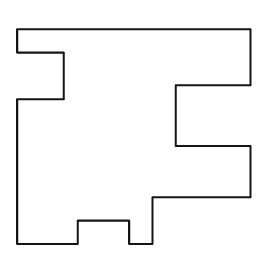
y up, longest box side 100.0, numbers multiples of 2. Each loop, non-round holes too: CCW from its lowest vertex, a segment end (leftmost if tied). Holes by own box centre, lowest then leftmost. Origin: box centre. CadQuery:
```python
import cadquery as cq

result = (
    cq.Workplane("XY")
    .moveTo(-50.0, -46.0)
    .lineTo(-24.0, -46.0)
    .lineTo(-24.0, -36.0)
    .lineTo(-2.0, -36.0)
    .lineTo(-2.0, -46.0)
    .lineTo(8.0, -46.0)
    .lineTo(8.0, -26.0)
    .lineTo(50.0, -26.0)
    .lineTo(50.0, -4.0)
    .lineTo(18.0, -4.0)
    .lineTo(18.0, 22.0)
    .lineTo(50.0, 22.0)
    .lineTo(50.0, 46.0)
    .lineTo(-50.0, 46.0)
    .lineTo(-50.0, 36.0)
    .lineTo(-30.0, 36.0)
    .lineTo(-30.0, 16.0)
    .lineTo(-50.0, 16.0)
    .close()
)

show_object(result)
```